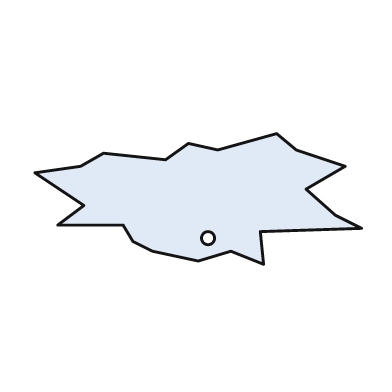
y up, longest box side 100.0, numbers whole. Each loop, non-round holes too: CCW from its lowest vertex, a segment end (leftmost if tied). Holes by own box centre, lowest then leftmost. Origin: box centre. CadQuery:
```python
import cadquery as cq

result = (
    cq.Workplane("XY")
    .moveTo(20.0, -20.0)
    .lineTo(19.0, -10.0)
    .lineTo(50.0, -9.0)
    .lineTo(42.0, -5.0)
    .lineTo(33.0, 3.0)
    .lineTo(45.0, 10.0)
    .lineTo(30.0, 15.0)
    .lineTo(24.0, 20.0)
    .lineTo(6.0, 15.0)
    .lineTo(-3.0, 17.0)
    .lineTo(-10.0, 12.0)
    .lineTo(-29.0, 14.0)
    .lineTo(-36.0, 10.0)
    .lineTo(-50.0, 8.0)
    .lineTo(-35.0, -2.0)
    .lineTo(-43.0, -8.0)
    .lineTo(-23.0, -8.0)
    .lineTo(-20.0, -13.0)
    .lineTo(-14.0, -16.0)
    .lineTo(0.0, -19.0)
    .lineTo(10.0, -16.0)
    .close()
    .moveTo(3.0, -12.0)
    .circle(2.0)
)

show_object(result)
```